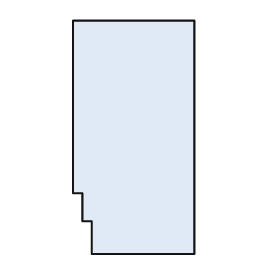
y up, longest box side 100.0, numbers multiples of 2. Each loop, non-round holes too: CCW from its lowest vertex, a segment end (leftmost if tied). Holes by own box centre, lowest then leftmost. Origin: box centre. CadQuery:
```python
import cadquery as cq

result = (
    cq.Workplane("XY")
    .moveTo(-18.0, -50.0)
    .lineTo(26.0, -50.0)
    .lineTo(26.0, 50.0)
    .lineTo(-26.0, 50.0)
    .lineTo(-26.0, -24.0)
    .lineTo(-22.0, -24.0)
    .lineTo(-22.0, -36.0)
    .lineTo(-18.0, -36.0)
    .close()
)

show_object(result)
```